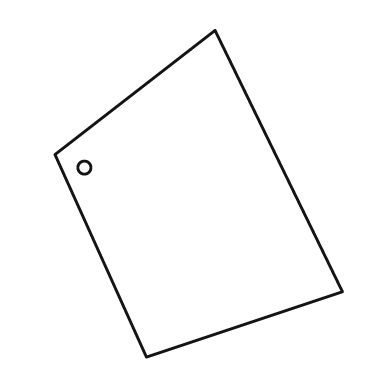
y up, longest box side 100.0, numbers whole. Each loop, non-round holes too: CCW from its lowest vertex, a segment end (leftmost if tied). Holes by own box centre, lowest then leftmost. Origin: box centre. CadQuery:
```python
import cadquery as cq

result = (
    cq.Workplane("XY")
    .moveTo(-16.0, -50.0)
    .lineTo(44.0, -30.0)
    .lineTo(5.0, 50.0)
    .lineTo(-44.0, 12.0)
    .close()
    .moveTo(-35.0, 8.0)
    .circle(2.0)
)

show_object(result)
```